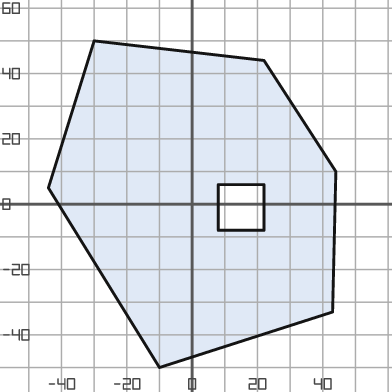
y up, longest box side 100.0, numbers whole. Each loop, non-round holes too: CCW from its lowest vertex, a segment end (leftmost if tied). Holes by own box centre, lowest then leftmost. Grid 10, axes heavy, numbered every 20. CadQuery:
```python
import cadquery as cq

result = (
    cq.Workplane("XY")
    .moveTo(-10.0, -50.0)
    .lineTo(43.0, -33.0)
    .lineTo(44.0, 10.0)
    .lineTo(22.0, 44.0)
    .lineTo(-30.0, 50.0)
    .lineTo(-44.0, 5.0)
    .close()
    .moveTo(8.0, -8.0)
    .lineTo(22.0, -8.0)
    .lineTo(22.0, 6.0)
    .lineTo(8.0, 6.0)
    .close()
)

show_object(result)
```